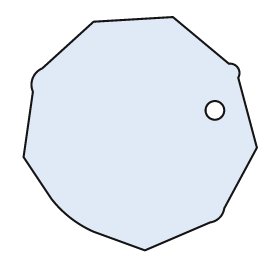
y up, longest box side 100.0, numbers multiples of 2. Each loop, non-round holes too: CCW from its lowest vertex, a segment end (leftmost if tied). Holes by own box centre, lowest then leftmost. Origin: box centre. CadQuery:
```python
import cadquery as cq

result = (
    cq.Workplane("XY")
    .moveTo(2.0, -50.0)
    .lineTo(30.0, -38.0)
    .threePointArc((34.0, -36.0), (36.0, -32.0))
    .lineTo(50.0, -6.0)
    .lineTo(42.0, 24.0)
    .threePointArc((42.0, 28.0), (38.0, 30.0))
    .lineTo(14.0, 50.0)
    .lineTo(-20.0, 48.0)
    .lineTo(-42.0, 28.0)
    .threePointArc((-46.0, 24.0), (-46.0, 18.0))
    .lineTo(-50.0, -10.0)
    .lineTo(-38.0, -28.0)
    .threePointArc((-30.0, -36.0), (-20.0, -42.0))
    .close()
    .moveTo(32.0, 10.0)
    .circle(4.0)
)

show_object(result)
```